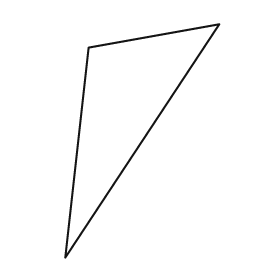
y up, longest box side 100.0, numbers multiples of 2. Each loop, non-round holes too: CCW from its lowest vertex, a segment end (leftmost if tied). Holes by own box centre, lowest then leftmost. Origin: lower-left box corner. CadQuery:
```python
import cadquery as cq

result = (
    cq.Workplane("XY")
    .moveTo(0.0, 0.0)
    .lineTo(66.0, 100.0)
    .lineTo(10.0, 90.0)
    .close()
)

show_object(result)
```